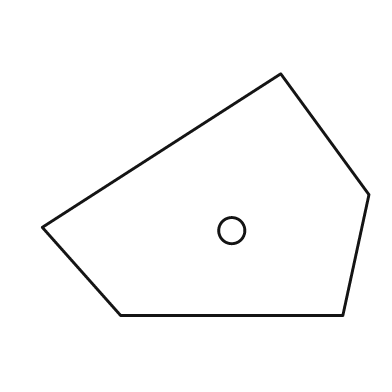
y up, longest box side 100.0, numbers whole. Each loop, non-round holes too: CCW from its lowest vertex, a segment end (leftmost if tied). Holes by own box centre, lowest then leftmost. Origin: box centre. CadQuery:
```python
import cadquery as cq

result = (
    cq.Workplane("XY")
    .moveTo(-26.0, -37.0)
    .lineTo(42.0, -37.0)
    .lineTo(50.0, 0.0)
    .lineTo(23.0, 37.0)
    .lineTo(-50.0, -10.0)
    .close()
    .moveTo(8.0, -11.0)
    .circle(4.0)
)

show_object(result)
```